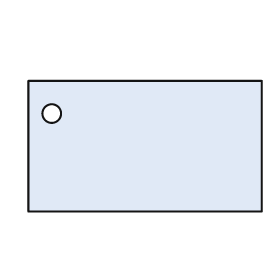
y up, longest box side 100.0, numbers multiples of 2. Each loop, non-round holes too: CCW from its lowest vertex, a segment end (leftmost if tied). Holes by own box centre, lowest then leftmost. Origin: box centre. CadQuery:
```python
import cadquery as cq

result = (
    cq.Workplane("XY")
    .moveTo(-50.0, -28.0)
    .lineTo(50.0, -28.0)
    .lineTo(50.0, 28.0)
    .lineTo(-50.0, 28.0)
    .close()
    .moveTo(-40.0, 14.0)
    .circle(4.0)
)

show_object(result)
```